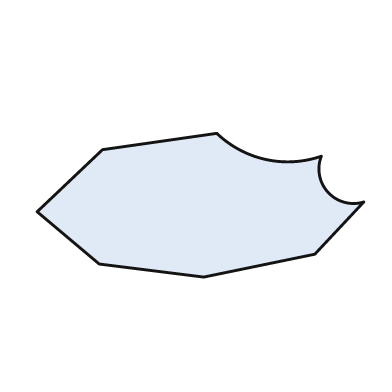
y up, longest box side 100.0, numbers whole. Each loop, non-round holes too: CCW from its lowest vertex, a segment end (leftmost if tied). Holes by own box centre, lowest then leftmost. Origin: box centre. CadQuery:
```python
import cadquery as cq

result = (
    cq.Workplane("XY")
    .moveTo(1.0, -22.0)
    .lineTo(35.0, -15.0)
    .lineTo(50.0, 1.0)
    .threePointArc((39.0, 4.0), (37.0, 15.0))
    .threePointArc((20.0, 14.0), (5.0, 22.0))
    .lineTo(-30.0, 17.0)
    .lineTo(-50.0, -2.0)
    .lineTo(-31.0, -18.0)
    .close()
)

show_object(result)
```